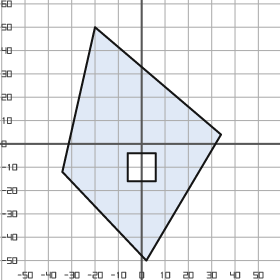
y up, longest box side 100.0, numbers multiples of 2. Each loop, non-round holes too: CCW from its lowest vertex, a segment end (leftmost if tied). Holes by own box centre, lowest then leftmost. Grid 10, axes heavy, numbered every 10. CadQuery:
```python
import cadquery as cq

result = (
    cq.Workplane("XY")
    .moveTo(2.0, -50.0)
    .lineTo(34.0, 4.0)
    .lineTo(-20.0, 50.0)
    .lineTo(-34.0, -12.0)
    .close()
    .moveTo(-6.0, -16.0)
    .lineTo(6.0, -16.0)
    .lineTo(6.0, -4.0)
    .lineTo(-6.0, -4.0)
    .close()
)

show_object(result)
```